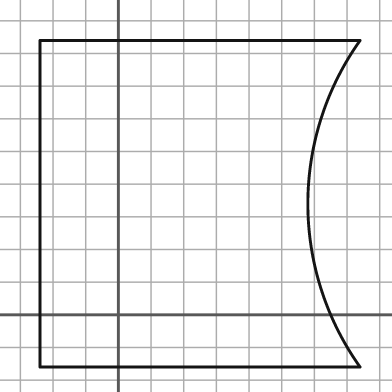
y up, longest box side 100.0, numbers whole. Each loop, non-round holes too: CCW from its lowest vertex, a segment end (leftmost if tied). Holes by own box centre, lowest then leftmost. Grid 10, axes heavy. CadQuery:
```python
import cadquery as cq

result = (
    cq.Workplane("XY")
    .moveTo(-24.0, -16.0)
    .lineTo(74.0, -16.0)
    .threePointArc((58.0, 34.0), (74.0, 84.0))
    .lineTo(-24.0, 84.0)
    .close()
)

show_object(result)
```